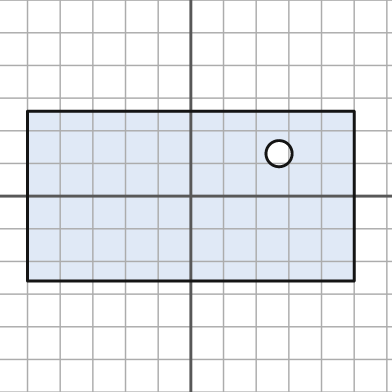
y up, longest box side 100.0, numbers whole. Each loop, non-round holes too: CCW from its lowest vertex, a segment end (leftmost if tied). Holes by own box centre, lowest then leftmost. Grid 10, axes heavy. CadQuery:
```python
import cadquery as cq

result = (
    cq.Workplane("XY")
    .moveTo(-50.0, -26.0)
    .lineTo(50.0, -26.0)
    .lineTo(50.0, 26.0)
    .lineTo(-50.0, 26.0)
    .close()
    .moveTo(27.0, 13.0)
    .circle(4.0)
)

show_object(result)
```